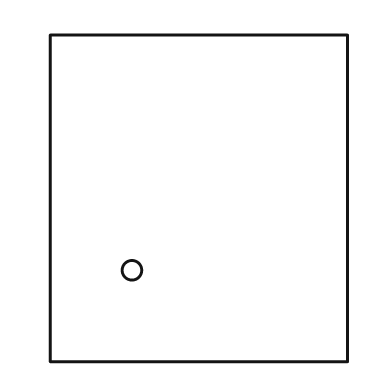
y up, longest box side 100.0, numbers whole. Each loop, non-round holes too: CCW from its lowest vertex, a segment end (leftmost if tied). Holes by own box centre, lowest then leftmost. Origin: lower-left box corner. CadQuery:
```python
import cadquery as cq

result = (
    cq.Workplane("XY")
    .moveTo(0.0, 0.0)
    .lineTo(91.0, 0.0)
    .lineTo(91.0, 100.0)
    .lineTo(0.0, 100.0)
    .close()
    .moveTo(25.0, 28.0)
    .circle(3.0)
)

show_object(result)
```